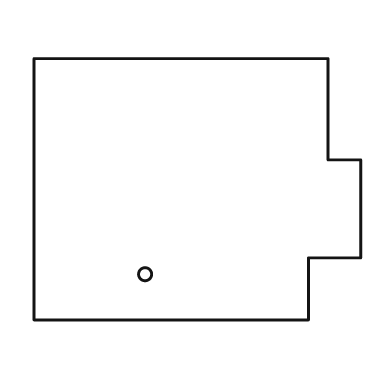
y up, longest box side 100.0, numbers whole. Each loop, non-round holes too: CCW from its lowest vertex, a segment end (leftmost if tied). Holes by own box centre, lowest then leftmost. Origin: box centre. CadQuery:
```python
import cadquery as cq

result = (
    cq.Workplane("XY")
    .moveTo(-50.0, -40.0)
    .lineTo(34.0, -40.0)
    .lineTo(34.0, -21.0)
    .lineTo(50.0, -21.0)
    .lineTo(50.0, 9.0)
    .lineTo(40.0, 9.0)
    .lineTo(40.0, 40.0)
    .lineTo(-50.0, 40.0)
    .close()
    .moveTo(-16.0, -26.0)
    .circle(2.0)
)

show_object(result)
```